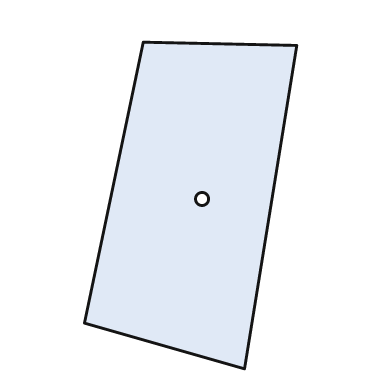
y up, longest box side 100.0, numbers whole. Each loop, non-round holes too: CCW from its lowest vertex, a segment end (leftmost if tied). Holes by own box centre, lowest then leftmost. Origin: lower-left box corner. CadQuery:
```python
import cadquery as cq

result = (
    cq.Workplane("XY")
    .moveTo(49.0, 0.0)
    .lineTo(65.0, 99.0)
    .lineTo(18.0, 100.0)
    .lineTo(0.0, 14.0)
    .close()
    .moveTo(36.0, 52.0)
    .circle(2.0)
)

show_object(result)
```